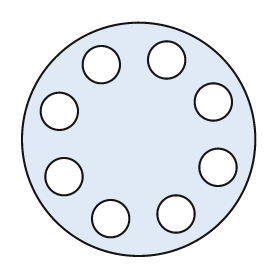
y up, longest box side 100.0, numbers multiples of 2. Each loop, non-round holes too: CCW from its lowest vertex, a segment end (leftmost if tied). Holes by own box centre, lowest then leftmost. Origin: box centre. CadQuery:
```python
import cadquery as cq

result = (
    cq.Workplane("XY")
    .moveTo(0.0, 0.0)
    .circle(50.0)
    .moveTo(-12.0, -34.0)
    .circle(8.0)
    .moveTo(16.0, -32.0)
    .circle(8.0)
    .moveTo(-32.0, -16.0)
    .circle(8.0)
    .moveTo(34.0, -12.0)
    .circle(8.0)
    .moveTo(-34.0, 12.0)
    .circle(8.0)
    .moveTo(32.0, 16.0)
    .circle(8.0)
    .moveTo(-16.0, 32.0)
    .circle(8.0)
    .moveTo(12.0, 34.0)
    .circle(8.0)
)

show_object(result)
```